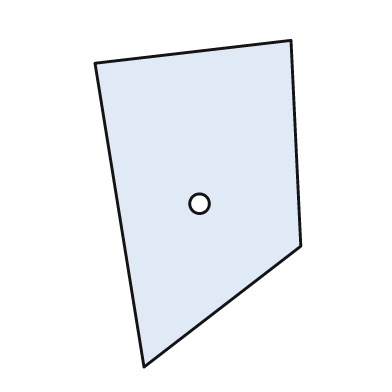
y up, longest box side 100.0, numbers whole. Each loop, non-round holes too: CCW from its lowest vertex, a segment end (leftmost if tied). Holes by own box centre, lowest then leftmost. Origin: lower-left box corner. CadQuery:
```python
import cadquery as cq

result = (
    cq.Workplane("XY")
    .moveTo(15.0, 0.0)
    .lineTo(63.0, 37.0)
    .lineTo(60.0, 100.0)
    .lineTo(0.0, 93.0)
    .close()
    .moveTo(32.0, 50.0)
    .circle(3.0)
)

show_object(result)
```